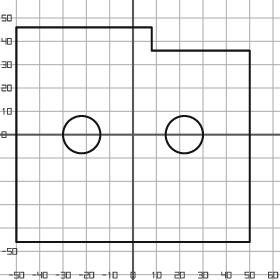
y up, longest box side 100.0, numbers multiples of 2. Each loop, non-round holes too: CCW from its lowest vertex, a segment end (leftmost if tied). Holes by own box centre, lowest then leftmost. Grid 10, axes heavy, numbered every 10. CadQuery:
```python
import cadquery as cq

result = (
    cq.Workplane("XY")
    .moveTo(-50.0, -46.0)
    .lineTo(50.0, -46.0)
    .lineTo(50.0, 36.0)
    .lineTo(8.0, 36.0)
    .lineTo(8.0, 46.0)
    .lineTo(-50.0, 46.0)
    .close()
    .moveTo(-22.0, 0.0)
    .circle(8.0)
    .moveTo(22.0, 0.0)
    .circle(8.0)
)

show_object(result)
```